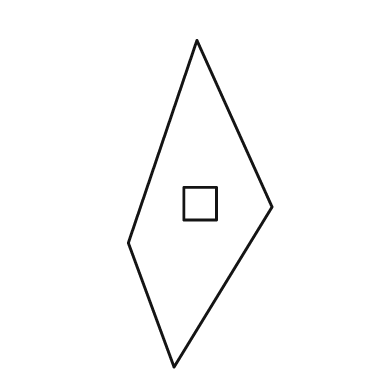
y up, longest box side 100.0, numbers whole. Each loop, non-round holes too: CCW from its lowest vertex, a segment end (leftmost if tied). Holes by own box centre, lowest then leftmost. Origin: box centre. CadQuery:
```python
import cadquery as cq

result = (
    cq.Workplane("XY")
    .moveTo(-8.0, -50.0)
    .lineTo(22.0, -1.0)
    .lineTo(-1.0, 50.0)
    .lineTo(-22.0, -12.0)
    .close()
    .moveTo(-5.0, -5.0)
    .lineTo(5.0, -5.0)
    .lineTo(5.0, 5.0)
    .lineTo(-5.0, 5.0)
    .close()
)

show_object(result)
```